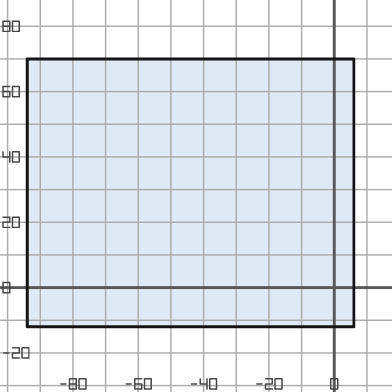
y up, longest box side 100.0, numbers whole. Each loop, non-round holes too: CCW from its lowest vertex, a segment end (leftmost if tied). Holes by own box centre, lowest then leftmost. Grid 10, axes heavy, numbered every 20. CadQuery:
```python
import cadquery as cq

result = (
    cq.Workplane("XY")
    .moveTo(-94.0, -12.0)
    .lineTo(6.0, -12.0)
    .lineTo(6.0, 70.0)
    .lineTo(-94.0, 70.0)
    .close()
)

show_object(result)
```